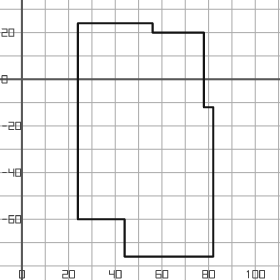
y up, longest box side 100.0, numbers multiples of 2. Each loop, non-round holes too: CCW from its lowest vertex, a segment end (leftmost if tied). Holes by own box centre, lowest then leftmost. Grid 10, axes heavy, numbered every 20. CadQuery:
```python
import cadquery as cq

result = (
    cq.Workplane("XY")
    .moveTo(44.0, -76.0)
    .lineTo(82.0, -76.0)
    .lineTo(82.0, -12.0)
    .lineTo(78.0, -12.0)
    .lineTo(78.0, 20.0)
    .lineTo(56.0, 20.0)
    .lineTo(56.0, 24.0)
    .lineTo(24.0, 24.0)
    .lineTo(24.0, -60.0)
    .lineTo(44.0, -60.0)
    .close()
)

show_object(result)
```